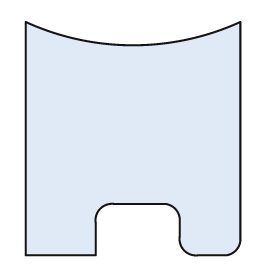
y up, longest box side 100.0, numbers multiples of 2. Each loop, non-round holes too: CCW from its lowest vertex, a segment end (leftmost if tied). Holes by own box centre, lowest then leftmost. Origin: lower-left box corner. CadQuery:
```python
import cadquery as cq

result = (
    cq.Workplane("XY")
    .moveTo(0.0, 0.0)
    .lineTo(30.0, 0.0)
    .lineTo(30.0, 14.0)
    .threePointArc((32.0, 20.0), (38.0, 22.0))
    .lineTo(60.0, 22.0)
    .threePointArc((64.0, 20.0), (66.0, 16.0))
    .lineTo(66.0, 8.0)
    .threePointArc((68.0, 2.0), (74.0, 0.0))
    .lineTo(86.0, 0.0)
    .threePointArc((90.0, 2.0), (92.0, 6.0))
    .lineTo(92.0, 100.0)
    .threePointArc((46.0, 90.0), (0.0, 100.0))
    .close()
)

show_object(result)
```